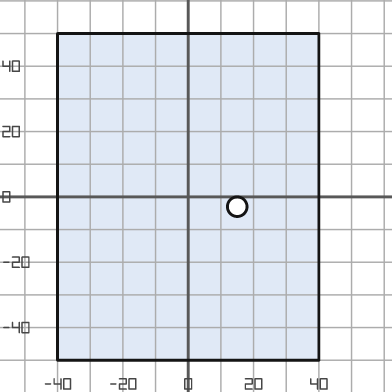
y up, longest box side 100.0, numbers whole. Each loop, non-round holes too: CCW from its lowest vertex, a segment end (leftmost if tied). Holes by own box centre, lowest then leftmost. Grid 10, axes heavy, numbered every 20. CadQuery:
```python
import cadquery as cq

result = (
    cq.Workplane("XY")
    .moveTo(-40.0, -50.0)
    .lineTo(40.0, -50.0)
    .lineTo(40.0, 50.0)
    .lineTo(-40.0, 50.0)
    .close()
    .moveTo(15.0, -3.0)
    .circle(3.0)
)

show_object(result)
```